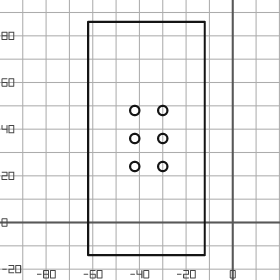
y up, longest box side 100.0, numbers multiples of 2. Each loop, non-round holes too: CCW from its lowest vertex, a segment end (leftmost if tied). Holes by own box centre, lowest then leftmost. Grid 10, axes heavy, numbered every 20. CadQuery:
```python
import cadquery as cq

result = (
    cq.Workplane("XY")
    .moveTo(-62.0, -14.0)
    .lineTo(-12.0, -14.0)
    .lineTo(-12.0, 86.0)
    .lineTo(-62.0, 86.0)
    .close()
    .moveTo(-42.0, 24.0)
    .circle(2.0)
    .moveTo(-30.0, 24.0)
    .circle(2.0)
    .moveTo(-42.0, 36.0)
    .circle(2.0)
    .moveTo(-30.0, 36.0)
    .circle(2.0)
    .moveTo(-42.0, 48.0)
    .circle(2.0)
    .moveTo(-30.0, 48.0)
    .circle(2.0)
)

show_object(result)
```